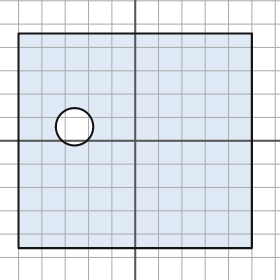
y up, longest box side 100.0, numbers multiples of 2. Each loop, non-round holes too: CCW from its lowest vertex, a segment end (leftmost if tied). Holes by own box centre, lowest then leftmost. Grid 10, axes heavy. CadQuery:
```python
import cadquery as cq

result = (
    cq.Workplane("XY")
    .moveTo(-50.0, -46.0)
    .lineTo(50.0, -46.0)
    .lineTo(50.0, 46.0)
    .lineTo(-50.0, 46.0)
    .close()
    .moveTo(-26.0, 6.0)
    .circle(8.0)
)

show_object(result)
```